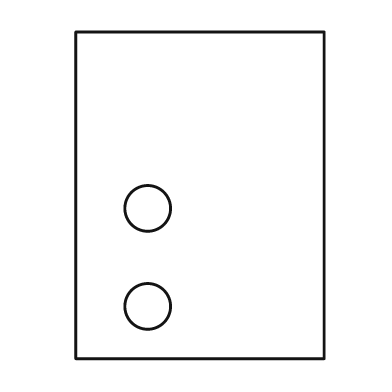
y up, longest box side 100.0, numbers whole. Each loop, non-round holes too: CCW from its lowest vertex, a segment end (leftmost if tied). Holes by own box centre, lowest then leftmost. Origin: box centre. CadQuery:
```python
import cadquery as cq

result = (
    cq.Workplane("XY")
    .moveTo(-38.0, -50.0)
    .lineTo(38.0, -50.0)
    .lineTo(38.0, 50.0)
    .lineTo(-38.0, 50.0)
    .close()
    .moveTo(-16.0, -34.0)
    .circle(7.0)
    .moveTo(-16.0, -4.0)
    .circle(7.0)
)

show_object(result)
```